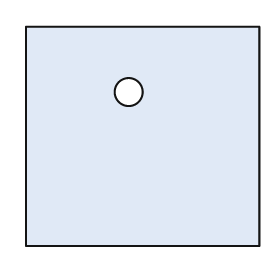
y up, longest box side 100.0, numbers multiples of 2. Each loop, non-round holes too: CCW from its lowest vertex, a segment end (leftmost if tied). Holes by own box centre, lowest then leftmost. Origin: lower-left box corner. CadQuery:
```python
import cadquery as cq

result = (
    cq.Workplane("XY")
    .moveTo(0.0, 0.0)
    .lineTo(100.0, 0.0)
    .lineTo(100.0, 94.0)
    .lineTo(0.0, 94.0)
    .close()
    .moveTo(44.0, 66.0)
    .circle(6.0)
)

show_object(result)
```